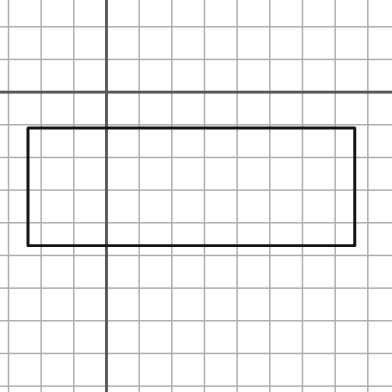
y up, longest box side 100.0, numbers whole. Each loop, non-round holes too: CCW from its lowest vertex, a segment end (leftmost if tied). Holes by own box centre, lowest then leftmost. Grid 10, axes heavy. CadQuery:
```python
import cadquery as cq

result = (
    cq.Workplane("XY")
    .moveTo(-24.0, -47.0)
    .lineTo(76.0, -47.0)
    .lineTo(76.0, -11.0)
    .lineTo(-24.0, -11.0)
    .close()
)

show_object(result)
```